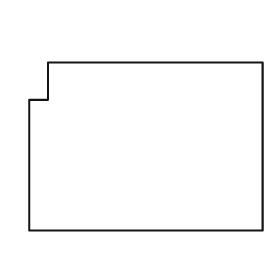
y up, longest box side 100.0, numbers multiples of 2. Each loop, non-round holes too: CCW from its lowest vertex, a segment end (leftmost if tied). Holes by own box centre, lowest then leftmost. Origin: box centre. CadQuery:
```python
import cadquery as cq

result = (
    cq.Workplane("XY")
    .moveTo(-50.0, -36.0)
    .lineTo(50.0, -36.0)
    .lineTo(50.0, 36.0)
    .lineTo(-42.0, 36.0)
    .lineTo(-42.0, 20.0)
    .lineTo(-50.0, 20.0)
    .close()
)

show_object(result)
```